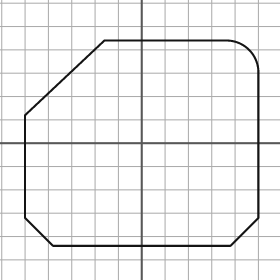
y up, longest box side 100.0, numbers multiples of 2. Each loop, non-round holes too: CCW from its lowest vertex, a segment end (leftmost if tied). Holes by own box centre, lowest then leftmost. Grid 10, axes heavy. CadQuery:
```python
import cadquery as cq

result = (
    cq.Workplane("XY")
    .moveTo(-38.0, -44.0)
    .lineTo(38.0, -44.0)
    .lineTo(50.0, -32.0)
    .lineTo(50.0, 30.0)
    .threePointArc((46.0, 40.0), (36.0, 44.0))
    .lineTo(-16.0, 44.0)
    .lineTo(-50.0, 12.0)
    .lineTo(-50.0, -32.0)
    .close()
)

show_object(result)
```